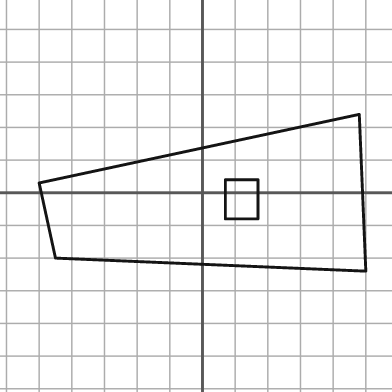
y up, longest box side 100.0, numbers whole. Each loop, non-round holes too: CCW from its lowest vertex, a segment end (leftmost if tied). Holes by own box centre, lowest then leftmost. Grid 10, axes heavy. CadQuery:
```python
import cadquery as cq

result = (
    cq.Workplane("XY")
    .moveTo(50.0, -24.0)
    .lineTo(48.0, 24.0)
    .lineTo(-50.0, 3.0)
    .lineTo(-45.0, -20.0)
    .close()
    .moveTo(7.0, -8.0)
    .lineTo(17.0, -8.0)
    .lineTo(17.0, 4.0)
    .lineTo(7.0, 4.0)
    .close()
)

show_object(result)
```